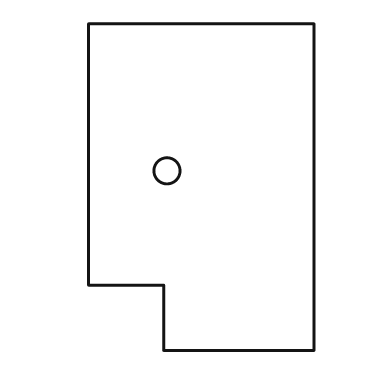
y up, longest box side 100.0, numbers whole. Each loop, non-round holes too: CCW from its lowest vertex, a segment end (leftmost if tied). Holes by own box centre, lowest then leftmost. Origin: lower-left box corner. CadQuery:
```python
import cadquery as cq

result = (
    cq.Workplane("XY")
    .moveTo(23.0, 0.0)
    .lineTo(69.0, 0.0)
    .lineTo(69.0, 100.0)
    .lineTo(0.0, 100.0)
    .lineTo(0.0, 20.0)
    .lineTo(23.0, 20.0)
    .close()
    .moveTo(24.0, 55.0)
    .circle(4.0)
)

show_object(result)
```